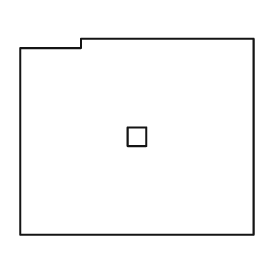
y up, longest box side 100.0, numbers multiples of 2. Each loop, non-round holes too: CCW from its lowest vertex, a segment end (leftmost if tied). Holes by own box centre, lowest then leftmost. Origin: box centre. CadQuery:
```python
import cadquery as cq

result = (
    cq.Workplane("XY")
    .moveTo(-50.0, -42.0)
    .lineTo(50.0, -42.0)
    .lineTo(50.0, 42.0)
    .lineTo(-24.0, 42.0)
    .lineTo(-24.0, 38.0)
    .lineTo(-50.0, 38.0)
    .close()
    .moveTo(-4.0, -4.0)
    .lineTo(4.0, -4.0)
    .lineTo(4.0, 4.0)
    .lineTo(-4.0, 4.0)
    .close()
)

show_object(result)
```